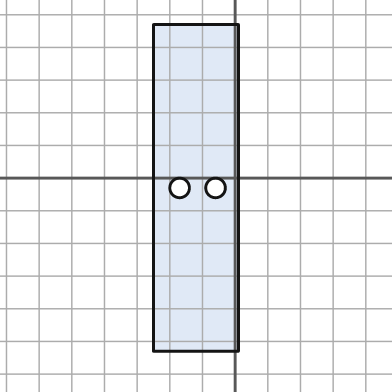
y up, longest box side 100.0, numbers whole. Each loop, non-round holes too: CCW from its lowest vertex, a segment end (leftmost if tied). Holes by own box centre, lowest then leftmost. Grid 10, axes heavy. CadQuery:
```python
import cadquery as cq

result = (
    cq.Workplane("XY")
    .moveTo(-25.0, -53.0)
    .lineTo(1.0, -53.0)
    .lineTo(1.0, 47.0)
    .lineTo(-25.0, 47.0)
    .close()
    .moveTo(-17.0, -3.0)
    .circle(3.0)
    .moveTo(-6.0, -3.0)
    .circle(3.0)
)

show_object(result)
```